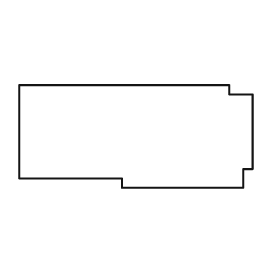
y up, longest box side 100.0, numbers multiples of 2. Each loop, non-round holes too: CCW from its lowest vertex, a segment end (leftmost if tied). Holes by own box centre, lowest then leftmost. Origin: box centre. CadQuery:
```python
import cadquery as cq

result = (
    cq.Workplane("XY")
    .moveTo(-6.0, -22.0)
    .lineTo(46.0, -22.0)
    .lineTo(46.0, -14.0)
    .lineTo(50.0, -14.0)
    .lineTo(50.0, 18.0)
    .lineTo(40.0, 18.0)
    .lineTo(40.0, 22.0)
    .lineTo(-50.0, 22.0)
    .lineTo(-50.0, -18.0)
    .lineTo(-6.0, -18.0)
    .close()
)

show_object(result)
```